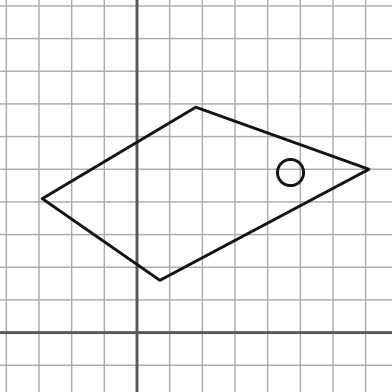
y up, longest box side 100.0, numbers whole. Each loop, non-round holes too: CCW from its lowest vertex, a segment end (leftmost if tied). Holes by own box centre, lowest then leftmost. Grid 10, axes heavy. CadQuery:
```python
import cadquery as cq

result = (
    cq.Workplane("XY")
    .moveTo(7.0, 16.0)
    .lineTo(71.0, 50.0)
    .lineTo(18.0, 69.0)
    .lineTo(-29.0, 41.0)
    .close()
    .moveTo(47.0, 49.0)
    .circle(4.0)
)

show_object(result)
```